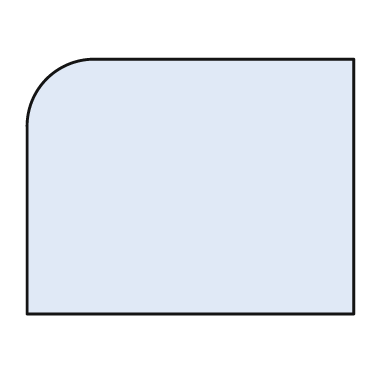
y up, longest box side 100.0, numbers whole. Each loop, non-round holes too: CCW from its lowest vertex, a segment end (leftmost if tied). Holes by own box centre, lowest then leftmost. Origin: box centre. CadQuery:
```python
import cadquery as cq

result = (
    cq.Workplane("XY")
    .moveTo(-50.0, -39.0)
    .lineTo(50.0, -39.0)
    .lineTo(50.0, 39.0)
    .lineTo(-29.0, 39.0)
    .threePointArc((-44.0, 33.0), (-50.0, 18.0))
    .close()
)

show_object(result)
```